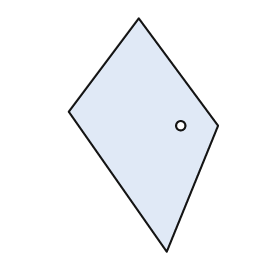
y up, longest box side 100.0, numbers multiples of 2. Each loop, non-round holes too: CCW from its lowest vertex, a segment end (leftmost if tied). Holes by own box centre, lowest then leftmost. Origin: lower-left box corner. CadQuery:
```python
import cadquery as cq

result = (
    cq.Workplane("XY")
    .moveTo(42.0, 0.0)
    .lineTo(64.0, 54.0)
    .lineTo(30.0, 100.0)
    .lineTo(0.0, 60.0)
    .close()
    .moveTo(48.0, 54.0)
    .circle(2.0)
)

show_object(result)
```